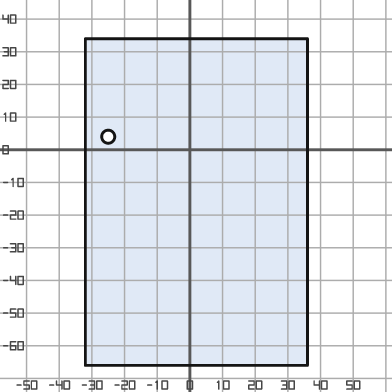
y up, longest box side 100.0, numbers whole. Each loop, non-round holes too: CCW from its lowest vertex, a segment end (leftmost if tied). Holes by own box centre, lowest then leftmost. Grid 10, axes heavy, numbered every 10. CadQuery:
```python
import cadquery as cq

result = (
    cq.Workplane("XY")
    .moveTo(-32.0, -66.0)
    .lineTo(36.0, -66.0)
    .lineTo(36.0, 34.0)
    .lineTo(-32.0, 34.0)
    .close()
    .moveTo(-25.0, 4.0)
    .circle(2.0)
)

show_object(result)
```